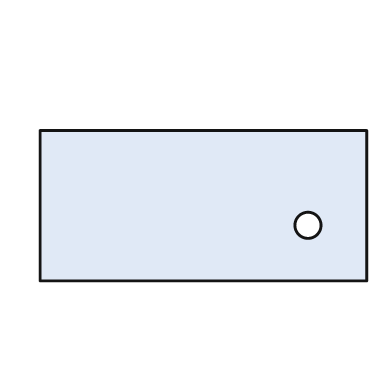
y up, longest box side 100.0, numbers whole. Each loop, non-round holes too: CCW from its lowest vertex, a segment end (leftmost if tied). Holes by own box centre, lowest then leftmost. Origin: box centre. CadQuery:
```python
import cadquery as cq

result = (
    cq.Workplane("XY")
    .moveTo(-50.0, -23.0)
    .lineTo(50.0, -23.0)
    .lineTo(50.0, 23.0)
    .lineTo(-50.0, 23.0)
    .close()
    .moveTo(32.0, -6.0)
    .circle(4.0)
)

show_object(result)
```